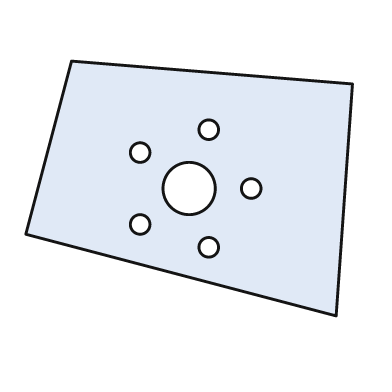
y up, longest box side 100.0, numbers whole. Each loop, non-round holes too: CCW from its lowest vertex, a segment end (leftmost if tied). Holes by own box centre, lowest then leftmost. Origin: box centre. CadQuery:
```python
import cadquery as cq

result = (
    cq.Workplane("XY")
    .moveTo(45.0, -39.0)
    .lineTo(50.0, 32.0)
    .lineTo(-36.0, 39.0)
    .lineTo(-50.0, -14.0)
    .close()
    .moveTo(6.0, -18.0)
    .circle(3.0)
    .moveTo(-15.0, -11.0)
    .circle(3.0)
    .moveTo(0.0, 0.0)
    .circle(8.0)
    .moveTo(19.0, 0.0)
    .circle(3.0)
    .moveTo(-15.0, 11.0)
    .circle(3.0)
    .moveTo(6.0, 18.0)
    .circle(3.0)
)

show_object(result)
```